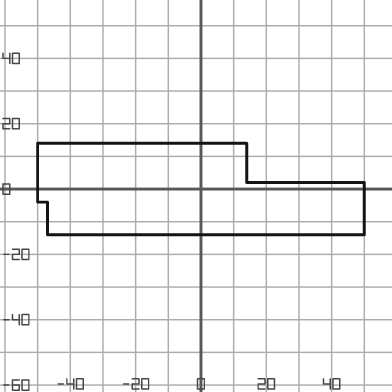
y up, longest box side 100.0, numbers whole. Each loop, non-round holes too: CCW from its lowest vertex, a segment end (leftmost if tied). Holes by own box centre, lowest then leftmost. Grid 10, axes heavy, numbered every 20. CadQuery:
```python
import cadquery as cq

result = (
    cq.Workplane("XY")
    .moveTo(-47.0, -14.0)
    .lineTo(50.0, -14.0)
    .lineTo(50.0, 2.0)
    .lineTo(14.0, 2.0)
    .lineTo(14.0, 14.0)
    .lineTo(-50.0, 14.0)
    .lineTo(-50.0, -4.0)
    .lineTo(-47.0, -4.0)
    .close()
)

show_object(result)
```